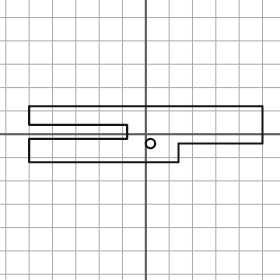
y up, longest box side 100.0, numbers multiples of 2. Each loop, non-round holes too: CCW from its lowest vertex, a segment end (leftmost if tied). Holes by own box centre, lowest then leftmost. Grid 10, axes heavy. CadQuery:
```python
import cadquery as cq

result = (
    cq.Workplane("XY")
    .moveTo(-50.0, -12.0)
    .lineTo(14.0, -12.0)
    .lineTo(14.0, -4.0)
    .lineTo(50.0, -4.0)
    .lineTo(50.0, 12.0)
    .lineTo(-50.0, 12.0)
    .lineTo(-50.0, 4.0)
    .lineTo(-8.0, 4.0)
    .lineTo(-8.0, -2.0)
    .lineTo(-50.0, -2.0)
    .close()
    .moveTo(2.0, -4.0)
    .circle(2.0)
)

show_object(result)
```